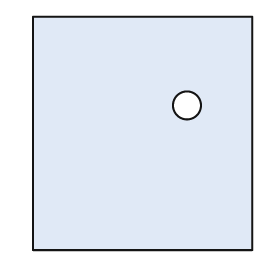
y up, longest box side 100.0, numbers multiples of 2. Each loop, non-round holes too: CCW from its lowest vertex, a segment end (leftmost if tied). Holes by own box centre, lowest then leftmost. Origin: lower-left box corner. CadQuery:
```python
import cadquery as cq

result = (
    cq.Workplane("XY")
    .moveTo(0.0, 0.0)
    .lineTo(94.0, 0.0)
    .lineTo(94.0, 100.0)
    .lineTo(0.0, 100.0)
    .close()
    .moveTo(66.0, 62.0)
    .circle(6.0)
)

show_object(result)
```